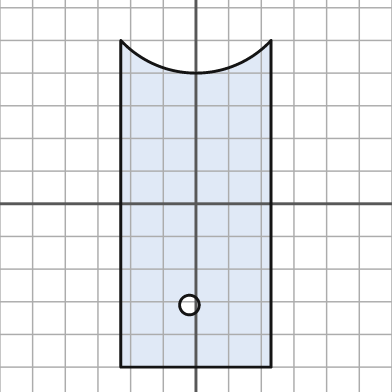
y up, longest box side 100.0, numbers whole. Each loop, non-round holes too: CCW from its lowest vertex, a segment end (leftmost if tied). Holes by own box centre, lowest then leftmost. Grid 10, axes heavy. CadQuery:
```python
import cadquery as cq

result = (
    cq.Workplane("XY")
    .moveTo(-23.0, -50.0)
    .lineTo(23.0, -50.0)
    .lineTo(23.0, 50.0)
    .threePointArc((0.0, 40.0), (-23.0, 50.0))
    .close()
    .moveTo(-2.0, -31.0)
    .circle(3.0)
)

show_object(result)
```